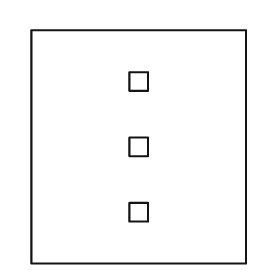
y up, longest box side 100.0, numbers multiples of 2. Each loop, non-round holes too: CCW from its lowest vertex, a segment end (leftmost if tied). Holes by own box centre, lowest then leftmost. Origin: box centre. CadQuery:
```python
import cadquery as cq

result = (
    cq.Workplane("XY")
    .moveTo(-46.0, -50.0)
    .lineTo(46.0, -50.0)
    .lineTo(46.0, 50.0)
    .lineTo(-46.0, 50.0)
    .close()
    .moveTo(-4.0, -32.0)
    .lineTo(4.0, -32.0)
    .lineTo(4.0, -24.0)
    .lineTo(-4.0, -24.0)
    .close()
    .moveTo(-4.0, -4.0)
    .lineTo(4.0, -4.0)
    .lineTo(4.0, 4.0)
    .lineTo(-4.0, 4.0)
    .close()
    .moveTo(-4.0, 24.0)
    .lineTo(4.0, 24.0)
    .lineTo(4.0, 32.0)
    .lineTo(-4.0, 32.0)
    .close()
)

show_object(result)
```